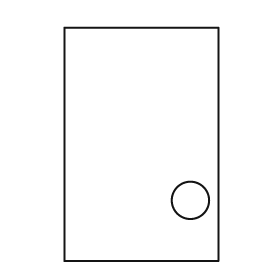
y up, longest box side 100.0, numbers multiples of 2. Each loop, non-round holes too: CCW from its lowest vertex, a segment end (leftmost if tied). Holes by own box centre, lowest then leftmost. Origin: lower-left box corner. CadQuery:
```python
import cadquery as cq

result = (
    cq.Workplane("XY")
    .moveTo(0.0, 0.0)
    .lineTo(66.0, 0.0)
    .lineTo(66.0, 100.0)
    .lineTo(0.0, 100.0)
    .close()
    .moveTo(54.0, 26.0)
    .circle(8.0)
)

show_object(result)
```